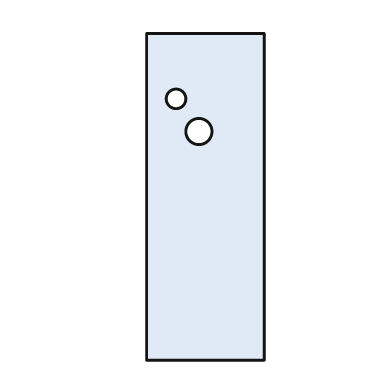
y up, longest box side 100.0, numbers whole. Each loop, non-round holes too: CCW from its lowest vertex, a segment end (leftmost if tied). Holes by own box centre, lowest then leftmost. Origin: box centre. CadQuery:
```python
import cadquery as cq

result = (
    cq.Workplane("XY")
    .moveTo(-18.0, -50.0)
    .lineTo(18.0, -50.0)
    .lineTo(18.0, 50.0)
    .lineTo(-18.0, 50.0)
    .close()
    .moveTo(-2.0, 20.0)
    .circle(4.0)
    .moveTo(-9.0, 30.0)
    .circle(3.0)
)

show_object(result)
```